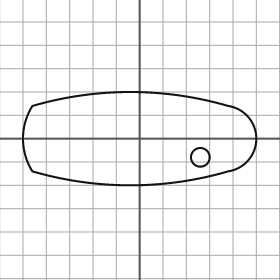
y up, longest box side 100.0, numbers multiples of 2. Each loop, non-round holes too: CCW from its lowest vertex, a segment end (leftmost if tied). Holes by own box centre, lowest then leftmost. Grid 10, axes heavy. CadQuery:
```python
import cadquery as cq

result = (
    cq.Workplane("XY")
    .moveTo(-46.0, -14.0)
    .threePointArc((-4.0, -20.0), (38.0, -14.0))
    .threePointArc((50.0, 0.0), (38.0, 14.0))
    .threePointArc((-4.0, 20.0), (-46.0, 14.0))
    .threePointArc((-50.0, 0.0), (-46.0, -14.0))
    .close()
    .moveTo(26.0, -8.0)
    .circle(4.0)
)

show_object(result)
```